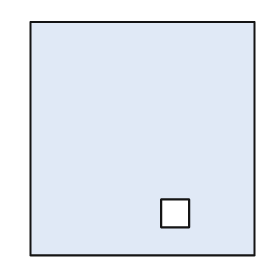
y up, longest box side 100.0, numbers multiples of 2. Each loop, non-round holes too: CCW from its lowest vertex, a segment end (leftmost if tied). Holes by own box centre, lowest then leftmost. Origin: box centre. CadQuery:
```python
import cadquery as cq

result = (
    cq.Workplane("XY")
    .moveTo(-48.0, -50.0)
    .lineTo(48.0, -50.0)
    .lineTo(48.0, 50.0)
    .lineTo(-48.0, 50.0)
    .close()
    .moveTo(8.0, -38.0)
    .lineTo(20.0, -38.0)
    .lineTo(20.0, -26.0)
    .lineTo(8.0, -26.0)
    .close()
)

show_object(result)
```